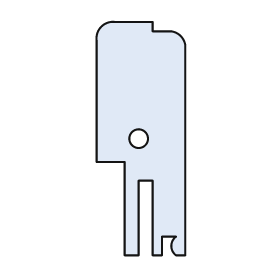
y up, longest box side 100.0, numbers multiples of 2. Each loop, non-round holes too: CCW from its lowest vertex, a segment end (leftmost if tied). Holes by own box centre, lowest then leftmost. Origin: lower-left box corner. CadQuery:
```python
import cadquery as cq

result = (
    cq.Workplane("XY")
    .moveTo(12.0, 0.0)
    .lineTo(18.0, 0.0)
    .lineTo(18.0, 32.0)
    .lineTo(24.0, 32.0)
    .lineTo(24.0, 0.0)
    .lineTo(28.0, 0.0)
    .lineTo(28.0, 8.0)
    .lineTo(34.0, 8.0)
    .threePointArc((32.0, 4.0), (34.0, 0.0))
    .lineTo(38.0, 0.0)
    .lineTo(38.0, 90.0)
    .threePointArc((36.0, 94.0), (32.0, 96.0))
    .lineTo(24.0, 96.0)
    .lineTo(24.0, 100.0)
    .lineTo(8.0, 100.0)
    .threePointArc((2.0, 98.0), (0.0, 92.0))
    .lineTo(0.0, 40.0)
    .lineTo(12.0, 40.0)
    .close()
    .moveTo(18.0, 50.0)
    .circle(4.0)
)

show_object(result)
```